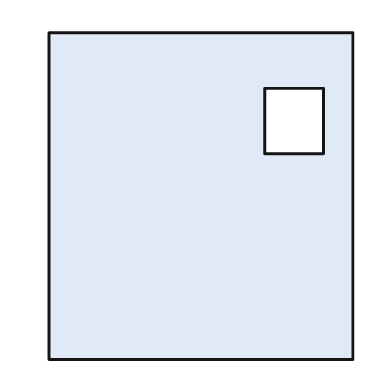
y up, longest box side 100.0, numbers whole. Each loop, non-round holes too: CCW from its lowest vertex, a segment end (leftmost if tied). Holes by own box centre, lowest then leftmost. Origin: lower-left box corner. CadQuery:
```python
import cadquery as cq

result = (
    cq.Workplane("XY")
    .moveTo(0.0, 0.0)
    .lineTo(93.0, 0.0)
    .lineTo(93.0, 100.0)
    .lineTo(0.0, 100.0)
    .close()
    .moveTo(66.0, 63.0)
    .lineTo(84.0, 63.0)
    .lineTo(84.0, 83.0)
    .lineTo(66.0, 83.0)
    .close()
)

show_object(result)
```